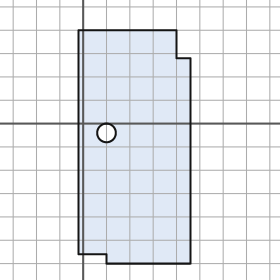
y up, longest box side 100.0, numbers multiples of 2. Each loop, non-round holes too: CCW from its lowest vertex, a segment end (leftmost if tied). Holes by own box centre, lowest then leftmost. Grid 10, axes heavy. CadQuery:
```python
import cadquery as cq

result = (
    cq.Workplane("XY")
    .moveTo(10.0, -60.0)
    .lineTo(46.0, -60.0)
    .lineTo(46.0, 28.0)
    .lineTo(40.0, 28.0)
    .lineTo(40.0, 40.0)
    .lineTo(-2.0, 40.0)
    .lineTo(-2.0, -56.0)
    .lineTo(10.0, -56.0)
    .close()
    .moveTo(10.0, -4.0)
    .circle(4.0)
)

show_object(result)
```